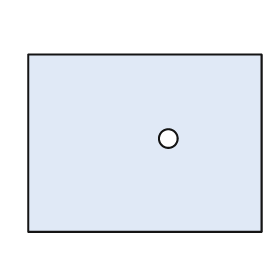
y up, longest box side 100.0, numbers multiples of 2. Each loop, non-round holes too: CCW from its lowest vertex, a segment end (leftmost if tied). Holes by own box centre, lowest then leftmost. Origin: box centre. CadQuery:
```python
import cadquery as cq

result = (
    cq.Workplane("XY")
    .moveTo(-50.0, -38.0)
    .lineTo(50.0, -38.0)
    .lineTo(50.0, 38.0)
    .lineTo(-50.0, 38.0)
    .close()
    .moveTo(10.0, 2.0)
    .circle(4.0)
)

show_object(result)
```